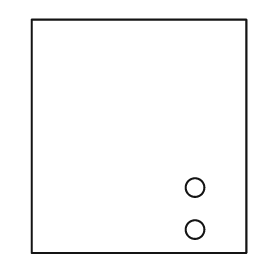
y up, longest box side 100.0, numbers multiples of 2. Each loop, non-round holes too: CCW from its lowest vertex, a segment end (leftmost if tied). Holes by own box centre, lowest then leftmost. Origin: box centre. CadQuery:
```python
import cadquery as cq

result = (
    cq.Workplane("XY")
    .moveTo(-46.0, -50.0)
    .lineTo(46.0, -50.0)
    .lineTo(46.0, 50.0)
    .lineTo(-46.0, 50.0)
    .close()
    .moveTo(24.0, -40.0)
    .circle(4.0)
    .moveTo(24.0, -22.0)
    .circle(4.0)
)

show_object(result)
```